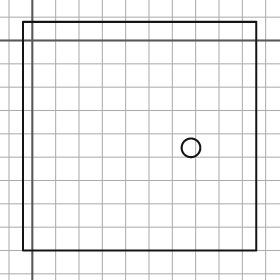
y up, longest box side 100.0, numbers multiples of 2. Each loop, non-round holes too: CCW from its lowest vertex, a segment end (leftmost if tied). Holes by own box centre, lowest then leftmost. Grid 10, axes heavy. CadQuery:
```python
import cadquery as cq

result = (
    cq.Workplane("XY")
    .moveTo(-4.0, -90.0)
    .lineTo(96.0, -90.0)
    .lineTo(96.0, 8.0)
    .lineTo(-4.0, 8.0)
    .close()
    .moveTo(68.0, -46.0)
    .circle(4.0)
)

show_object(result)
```